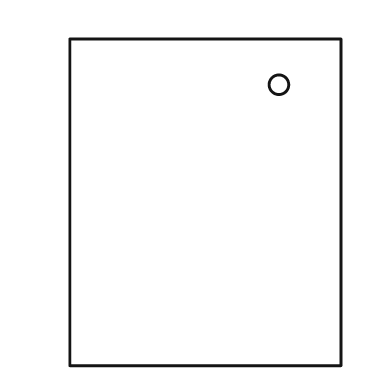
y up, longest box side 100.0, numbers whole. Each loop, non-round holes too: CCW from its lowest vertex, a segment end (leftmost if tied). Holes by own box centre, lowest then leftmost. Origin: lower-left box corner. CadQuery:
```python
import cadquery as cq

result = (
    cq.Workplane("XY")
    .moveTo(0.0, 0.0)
    .lineTo(83.0, 0.0)
    .lineTo(83.0, 100.0)
    .lineTo(0.0, 100.0)
    .close()
    .moveTo(64.0, 86.0)
    .circle(3.0)
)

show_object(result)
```